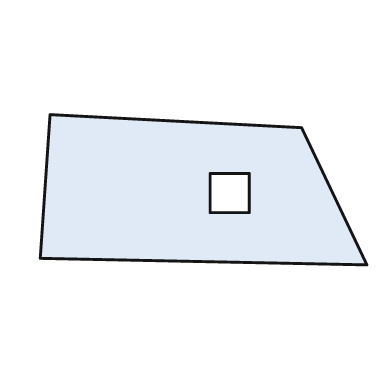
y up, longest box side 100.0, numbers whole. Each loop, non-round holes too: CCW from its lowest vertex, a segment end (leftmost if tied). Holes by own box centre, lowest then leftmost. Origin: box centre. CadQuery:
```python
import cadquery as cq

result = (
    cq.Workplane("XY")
    .moveTo(50.0, -23.0)
    .lineTo(30.0, 19.0)
    .lineTo(-47.0, 23.0)
    .lineTo(-50.0, -21.0)
    .close()
    .moveTo(2.0, -7.0)
    .lineTo(14.0, -7.0)
    .lineTo(14.0, 5.0)
    .lineTo(2.0, 5.0)
    .close()
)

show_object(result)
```